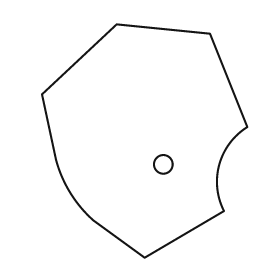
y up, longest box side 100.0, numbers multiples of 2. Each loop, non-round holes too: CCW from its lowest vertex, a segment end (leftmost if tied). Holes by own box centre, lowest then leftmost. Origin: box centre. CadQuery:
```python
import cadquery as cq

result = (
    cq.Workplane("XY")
    .moveTo(0.0, -50.0)
    .lineTo(34.0, -30.0)
    .threePointArc((32.0, -10.0), (44.0, 6.0))
    .lineTo(28.0, 46.0)
    .lineTo(-12.0, 50.0)
    .lineTo(-44.0, 20.0)
    .lineTo(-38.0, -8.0)
    .threePointArc((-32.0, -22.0), (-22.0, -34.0))
    .close()
    .moveTo(8.0, -10.0)
    .circle(4.0)
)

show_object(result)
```